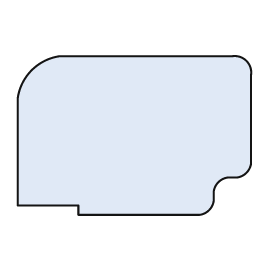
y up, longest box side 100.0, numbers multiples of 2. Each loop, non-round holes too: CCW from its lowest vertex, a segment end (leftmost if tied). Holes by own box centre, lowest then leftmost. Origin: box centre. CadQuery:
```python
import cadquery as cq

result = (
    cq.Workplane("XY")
    .moveTo(-24.0, -34.0)
    .lineTo(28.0, -34.0)
    .threePointArc((32.0, -32.0), (34.0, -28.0))
    .lineTo(34.0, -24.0)
    .threePointArc((36.0, -20.0), (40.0, -18.0))
    .lineTo(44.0, -18.0)
    .threePointArc((48.0, -16.0), (50.0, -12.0))
    .lineTo(50.0, 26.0)
    .threePointArc((48.0, 32.0), (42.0, 34.0))
    .lineTo(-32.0, 34.0)
    .threePointArc((-44.0, 28.0), (-50.0, 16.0))
    .lineTo(-50.0, -30.0)
    .lineTo(-24.0, -30.0)
    .close()
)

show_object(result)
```